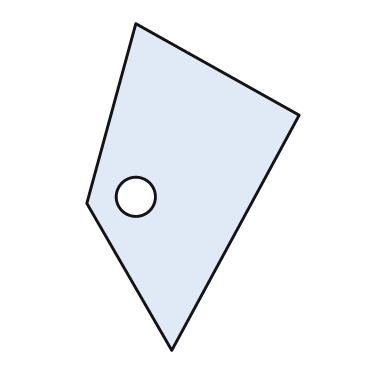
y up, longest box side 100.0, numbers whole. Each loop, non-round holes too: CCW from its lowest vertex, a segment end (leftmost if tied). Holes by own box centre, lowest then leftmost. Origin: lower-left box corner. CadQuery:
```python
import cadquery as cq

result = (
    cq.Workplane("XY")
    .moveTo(26.0, 0.0)
    .lineTo(65.0, 72.0)
    .lineTo(15.0, 100.0)
    .lineTo(0.0, 45.0)
    .close()
    .moveTo(15.0, 47.0)
    .circle(6.0)
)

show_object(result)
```